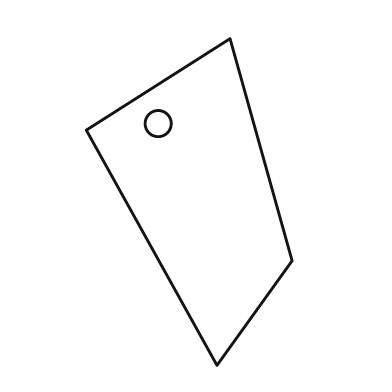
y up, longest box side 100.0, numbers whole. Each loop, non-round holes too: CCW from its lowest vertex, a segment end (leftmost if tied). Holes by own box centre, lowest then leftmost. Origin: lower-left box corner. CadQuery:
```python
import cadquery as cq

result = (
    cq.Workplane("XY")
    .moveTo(40.0, 0.0)
    .lineTo(63.0, 32.0)
    .lineTo(44.0, 100.0)
    .lineTo(0.0, 72.0)
    .close()
    .moveTo(22.0, 74.0)
    .circle(4.0)
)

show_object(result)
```